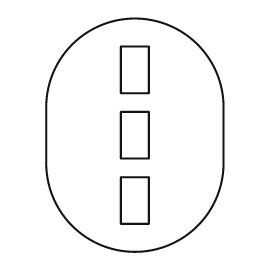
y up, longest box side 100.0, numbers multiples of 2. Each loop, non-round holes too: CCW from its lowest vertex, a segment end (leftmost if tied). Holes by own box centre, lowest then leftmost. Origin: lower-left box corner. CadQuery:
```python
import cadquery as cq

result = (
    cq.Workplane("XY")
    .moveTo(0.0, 38.0)
    .threePointArc((38.0, 0.0), (76.0, 38.0))
    .lineTo(76.0, 62.0)
    .threePointArc((38.0, 100.0), (0.0, 62.0))
    .close()
    .moveTo(32.0, 12.0)
    .lineTo(44.0, 12.0)
    .lineTo(44.0, 32.0)
    .lineTo(32.0, 32.0)
    .close()
    .moveTo(32.0, 40.0)
    .lineTo(44.0, 40.0)
    .lineTo(44.0, 60.0)
    .lineTo(32.0, 60.0)
    .close()
    .moveTo(32.0, 68.0)
    .lineTo(44.0, 68.0)
    .lineTo(44.0, 88.0)
    .lineTo(32.0, 88.0)
    .close()
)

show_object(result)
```